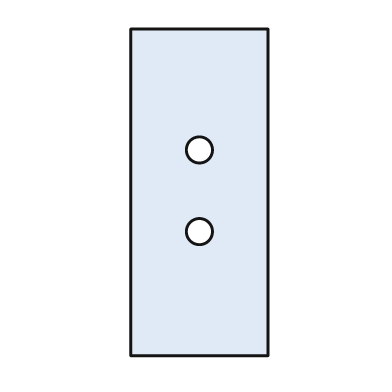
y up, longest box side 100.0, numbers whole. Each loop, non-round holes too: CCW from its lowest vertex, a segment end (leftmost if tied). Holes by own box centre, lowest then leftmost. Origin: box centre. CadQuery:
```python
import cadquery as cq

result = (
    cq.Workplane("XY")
    .moveTo(-21.0, -50.0)
    .lineTo(21.0, -50.0)
    .lineTo(21.0, 50.0)
    .lineTo(-21.0, 50.0)
    .close()
    .moveTo(0.0, -12.0)
    .circle(4.0)
    .moveTo(0.0, 13.0)
    .circle(4.0)
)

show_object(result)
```